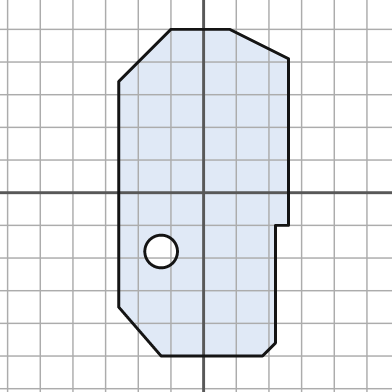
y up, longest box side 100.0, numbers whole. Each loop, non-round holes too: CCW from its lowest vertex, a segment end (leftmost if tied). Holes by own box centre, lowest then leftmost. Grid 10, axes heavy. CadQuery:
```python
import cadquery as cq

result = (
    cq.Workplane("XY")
    .moveTo(-13.0, -50.0)
    .lineTo(18.0, -50.0)
    .lineTo(22.0, -46.0)
    .lineTo(22.0, -10.0)
    .lineTo(26.0, -10.0)
    .lineTo(26.0, 41.0)
    .lineTo(8.0, 50.0)
    .lineTo(-10.0, 50.0)
    .lineTo(-26.0, 34.0)
    .lineTo(-26.0, -35.0)
    .close()
    .moveTo(-13.0, -18.0)
    .circle(5.0)
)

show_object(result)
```